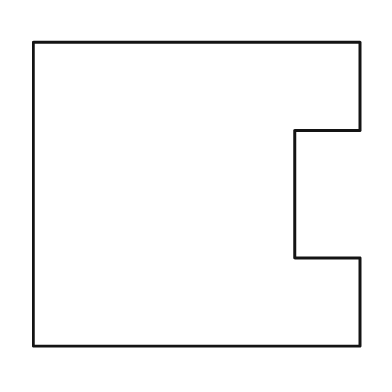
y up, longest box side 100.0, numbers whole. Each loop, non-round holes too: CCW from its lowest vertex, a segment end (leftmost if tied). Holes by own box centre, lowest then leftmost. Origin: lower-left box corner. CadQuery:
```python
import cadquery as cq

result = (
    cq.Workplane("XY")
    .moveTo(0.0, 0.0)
    .lineTo(100.0, 0.0)
    .lineTo(100.0, 27.0)
    .lineTo(80.0, 27.0)
    .lineTo(80.0, 66.0)
    .lineTo(100.0, 66.0)
    .lineTo(100.0, 93.0)
    .lineTo(0.0, 93.0)
    .close()
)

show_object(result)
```